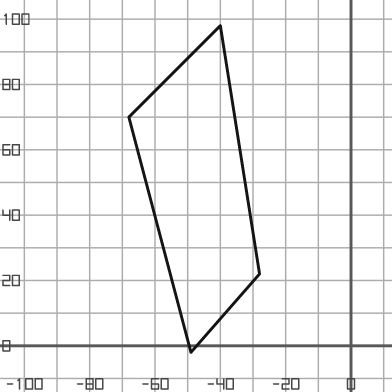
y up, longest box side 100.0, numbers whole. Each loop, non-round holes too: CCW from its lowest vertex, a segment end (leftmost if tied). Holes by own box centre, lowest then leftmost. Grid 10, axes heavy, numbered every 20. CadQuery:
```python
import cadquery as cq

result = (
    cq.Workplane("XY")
    .moveTo(-49.0, -2.0)
    .lineTo(-28.0, 22.0)
    .lineTo(-40.0, 98.0)
    .lineTo(-68.0, 70.0)
    .close()
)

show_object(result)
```